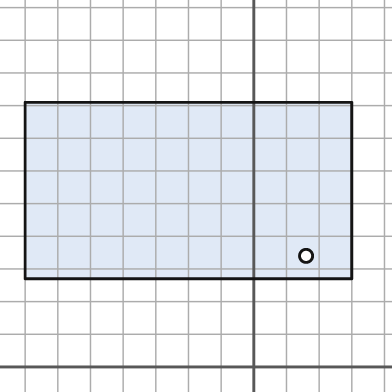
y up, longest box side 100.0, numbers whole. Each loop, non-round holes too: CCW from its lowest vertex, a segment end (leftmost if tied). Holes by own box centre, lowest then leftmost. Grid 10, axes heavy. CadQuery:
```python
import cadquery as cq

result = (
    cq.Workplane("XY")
    .moveTo(-70.0, 27.0)
    .lineTo(30.0, 27.0)
    .lineTo(30.0, 81.0)
    .lineTo(-70.0, 81.0)
    .close()
    .moveTo(16.0, 34.0)
    .circle(2.0)
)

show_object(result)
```